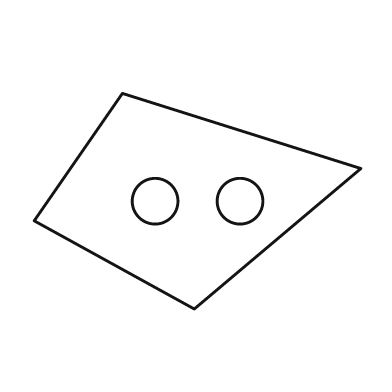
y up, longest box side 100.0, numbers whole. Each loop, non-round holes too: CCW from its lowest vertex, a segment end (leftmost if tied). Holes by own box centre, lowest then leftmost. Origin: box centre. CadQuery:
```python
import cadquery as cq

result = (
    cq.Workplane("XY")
    .moveTo(-1.0, -33.0)
    .lineTo(50.0, 10.0)
    .lineTo(-23.0, 33.0)
    .lineTo(-50.0, -6.0)
    .close()
    .moveTo(-13.0, 0.0)
    .circle(7.0)
    .moveTo(13.0, 0.0)
    .circle(7.0)
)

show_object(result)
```